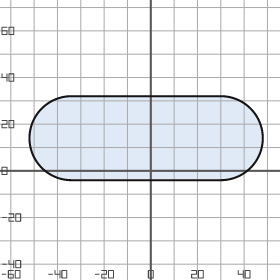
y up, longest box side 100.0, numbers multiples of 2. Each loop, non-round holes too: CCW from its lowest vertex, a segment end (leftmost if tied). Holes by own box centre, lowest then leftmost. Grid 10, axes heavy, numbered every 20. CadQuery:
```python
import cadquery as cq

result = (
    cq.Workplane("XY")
    .moveTo(-34.0, -4.0)
    .lineTo(30.0, -4.0)
    .threePointArc((48.0, 14.0), (30.0, 32.0))
    .lineTo(-34.0, 32.0)
    .threePointArc((-52.0, 14.0), (-34.0, -4.0))
    .close()
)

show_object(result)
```